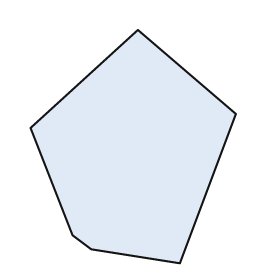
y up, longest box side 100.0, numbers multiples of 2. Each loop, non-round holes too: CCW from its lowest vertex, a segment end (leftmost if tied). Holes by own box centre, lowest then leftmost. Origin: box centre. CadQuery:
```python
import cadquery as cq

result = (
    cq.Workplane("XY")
    .moveTo(20.0, -50.0)
    .lineTo(44.0, 14.0)
    .lineTo(2.0, 50.0)
    .lineTo(-44.0, 8.0)
    .lineTo(-26.0, -38.0)
    .lineTo(-18.0, -44.0)
    .close()
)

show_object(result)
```